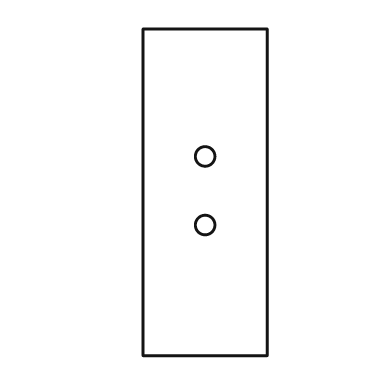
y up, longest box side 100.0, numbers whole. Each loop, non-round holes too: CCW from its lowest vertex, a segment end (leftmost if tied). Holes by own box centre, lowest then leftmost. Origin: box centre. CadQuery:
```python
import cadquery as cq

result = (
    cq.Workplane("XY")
    .moveTo(-19.0, -50.0)
    .lineTo(19.0, -50.0)
    .lineTo(19.0, 50.0)
    .lineTo(-19.0, 50.0)
    .close()
    .moveTo(0.0, -10.0)
    .circle(3.0)
    .moveTo(0.0, 11.0)
    .circle(3.0)
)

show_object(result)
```